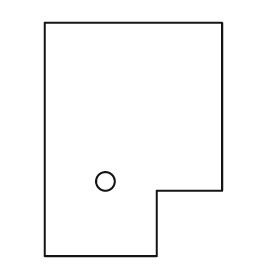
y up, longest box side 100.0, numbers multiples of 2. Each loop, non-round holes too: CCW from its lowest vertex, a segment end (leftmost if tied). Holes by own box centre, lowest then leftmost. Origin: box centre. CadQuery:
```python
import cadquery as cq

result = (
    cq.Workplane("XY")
    .moveTo(-38.0, -50.0)
    .lineTo(10.0, -50.0)
    .lineTo(10.0, -22.0)
    .lineTo(38.0, -22.0)
    .lineTo(38.0, 50.0)
    .lineTo(-38.0, 50.0)
    .close()
    .moveTo(-12.0, -18.0)
    .circle(4.0)
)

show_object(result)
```